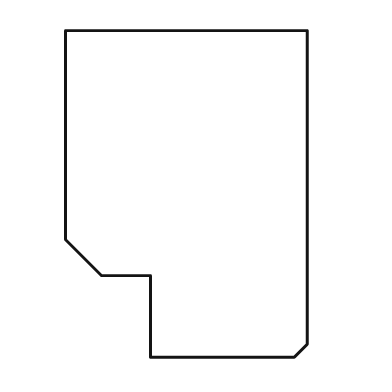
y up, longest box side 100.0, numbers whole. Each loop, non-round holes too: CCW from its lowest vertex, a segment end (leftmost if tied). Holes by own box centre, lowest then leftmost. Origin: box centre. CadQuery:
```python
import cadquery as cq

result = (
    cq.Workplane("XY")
    .moveTo(-11.0, -50.0)
    .lineTo(33.0, -50.0)
    .lineTo(37.0, -46.0)
    .lineTo(37.0, 50.0)
    .lineTo(-37.0, 50.0)
    .lineTo(-37.0, -14.0)
    .lineTo(-26.0, -25.0)
    .lineTo(-11.0, -25.0)
    .close()
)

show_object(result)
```